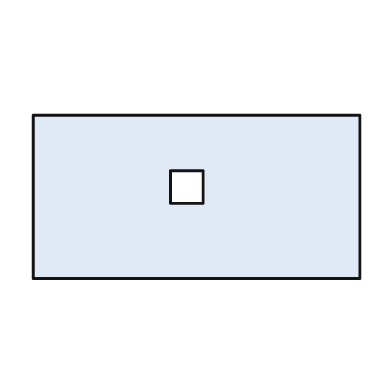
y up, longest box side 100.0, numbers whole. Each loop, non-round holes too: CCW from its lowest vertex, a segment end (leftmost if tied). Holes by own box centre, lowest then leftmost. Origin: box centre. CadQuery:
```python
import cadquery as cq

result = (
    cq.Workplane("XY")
    .moveTo(-50.0, -25.0)
    .lineTo(50.0, -25.0)
    .lineTo(50.0, 25.0)
    .lineTo(-50.0, 25.0)
    .close()
    .moveTo(-8.0, -2.0)
    .lineTo(2.0, -2.0)
    .lineTo(2.0, 8.0)
    .lineTo(-8.0, 8.0)
    .close()
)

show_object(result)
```